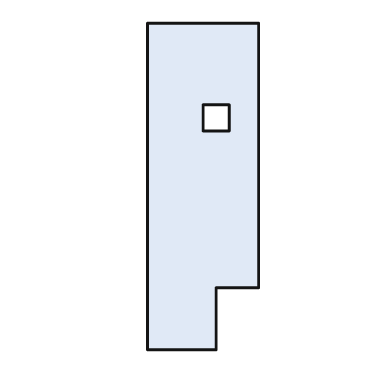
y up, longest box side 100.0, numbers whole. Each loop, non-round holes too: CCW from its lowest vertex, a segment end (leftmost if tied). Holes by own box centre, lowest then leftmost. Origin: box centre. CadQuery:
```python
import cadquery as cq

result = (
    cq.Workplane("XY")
    .moveTo(-17.0, -50.0)
    .lineTo(4.0, -50.0)
    .lineTo(4.0, -31.0)
    .lineTo(17.0, -31.0)
    .lineTo(17.0, 50.0)
    .lineTo(-17.0, 50.0)
    .close()
    .moveTo(0.0, 17.0)
    .lineTo(8.0, 17.0)
    .lineTo(8.0, 25.0)
    .lineTo(0.0, 25.0)
    .close()
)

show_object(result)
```